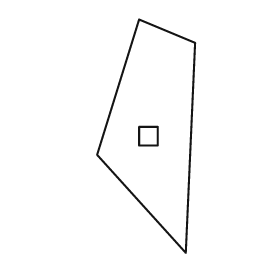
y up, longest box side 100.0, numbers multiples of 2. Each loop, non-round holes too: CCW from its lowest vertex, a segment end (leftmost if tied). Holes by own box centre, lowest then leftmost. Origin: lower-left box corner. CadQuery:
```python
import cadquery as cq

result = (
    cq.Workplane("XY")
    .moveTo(38.0, 0.0)
    .lineTo(42.0, 90.0)
    .lineTo(18.0, 100.0)
    .lineTo(0.0, 42.0)
    .close()
    .moveTo(18.0, 46.0)
    .lineTo(26.0, 46.0)
    .lineTo(26.0, 54.0)
    .lineTo(18.0, 54.0)
    .close()
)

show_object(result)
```